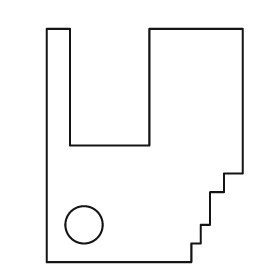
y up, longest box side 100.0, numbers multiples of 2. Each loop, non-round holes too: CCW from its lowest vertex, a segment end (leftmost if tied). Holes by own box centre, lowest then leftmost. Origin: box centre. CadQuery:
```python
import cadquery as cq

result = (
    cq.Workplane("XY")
    .moveTo(-42.0, -50.0)
    .lineTo(20.0, -50.0)
    .lineTo(20.0, -42.0)
    .lineTo(24.0, -42.0)
    .lineTo(24.0, -34.0)
    .lineTo(28.0, -34.0)
    .lineTo(28.0, -20.0)
    .lineTo(34.0, -20.0)
    .lineTo(34.0, -12.0)
    .lineTo(42.0, -12.0)
    .lineTo(42.0, 50.0)
    .lineTo(2.0, 50.0)
    .lineTo(2.0, 0.0)
    .lineTo(-32.0, 0.0)
    .lineTo(-32.0, 50.0)
    .lineTo(-42.0, 50.0)
    .close()
    .moveTo(-26.0, -34.0)
    .circle(8.0)
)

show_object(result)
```